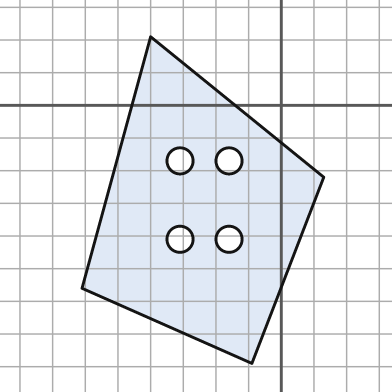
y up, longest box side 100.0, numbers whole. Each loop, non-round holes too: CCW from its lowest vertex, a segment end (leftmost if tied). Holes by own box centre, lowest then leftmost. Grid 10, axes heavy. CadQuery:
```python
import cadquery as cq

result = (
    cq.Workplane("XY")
    .moveTo(-9.0, -79.0)
    .lineTo(13.0, -22.0)
    .lineTo(-40.0, 21.0)
    .lineTo(-61.0, -56.0)
    .close()
    .moveTo(-31.0, -41.0)
    .circle(4.0)
    .moveTo(-16.0, -41.0)
    .circle(4.0)
    .moveTo(-31.0, -17.0)
    .circle(4.0)
    .moveTo(-16.0, -17.0)
    .circle(4.0)
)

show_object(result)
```